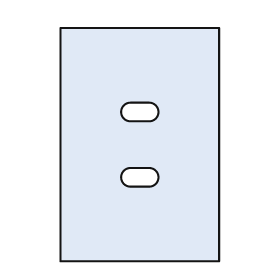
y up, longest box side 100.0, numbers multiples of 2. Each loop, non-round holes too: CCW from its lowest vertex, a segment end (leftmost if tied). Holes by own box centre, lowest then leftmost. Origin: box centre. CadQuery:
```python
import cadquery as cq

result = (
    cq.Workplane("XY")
    .moveTo(-34.0, -50.0)
    .lineTo(34.0, -50.0)
    .lineTo(34.0, 50.0)
    .lineTo(-34.0, 50.0)
    .close()
    .moveTo(-4.0, -18.0)
    .lineTo(4.0, -18.0)
    .threePointArc((8.0, -14.0), (4.0, -10.0))
    .lineTo(-4.0, -10.0)
    .threePointArc((-8.0, -14.0), (-4.0, -18.0))
    .close()
    .moveTo(-4.0, 10.0)
    .lineTo(4.0, 10.0)
    .threePointArc((8.0, 14.0), (4.0, 18.0))
    .lineTo(-4.0, 18.0)
    .threePointArc((-8.0, 14.0), (-4.0, 10.0))
    .close()
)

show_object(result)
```